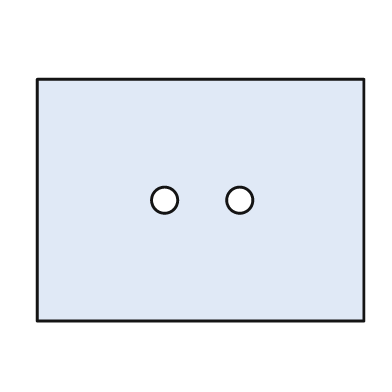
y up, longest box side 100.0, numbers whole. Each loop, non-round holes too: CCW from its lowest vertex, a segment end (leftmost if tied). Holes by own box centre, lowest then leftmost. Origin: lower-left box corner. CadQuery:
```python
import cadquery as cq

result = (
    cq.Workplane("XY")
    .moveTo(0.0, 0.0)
    .lineTo(100.0, 0.0)
    .lineTo(100.0, 74.0)
    .lineTo(0.0, 74.0)
    .close()
    .moveTo(39.0, 37.0)
    .circle(4.0)
    .moveTo(62.0, 37.0)
    .circle(4.0)
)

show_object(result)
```